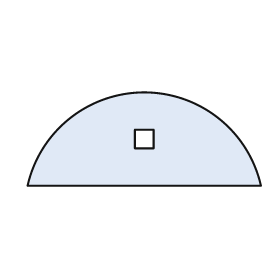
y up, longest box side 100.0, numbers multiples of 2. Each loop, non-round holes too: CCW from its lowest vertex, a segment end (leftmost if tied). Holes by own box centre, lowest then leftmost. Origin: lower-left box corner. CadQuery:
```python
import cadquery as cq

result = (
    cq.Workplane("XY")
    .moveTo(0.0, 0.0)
    .lineTo(100.0, 0.0)
    .threePointArc((50.0, 40.0), (0.0, 0.0))
    .close()
    .moveTo(46.0, 16.0)
    .lineTo(54.0, 16.0)
    .lineTo(54.0, 24.0)
    .lineTo(46.0, 24.0)
    .close()
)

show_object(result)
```